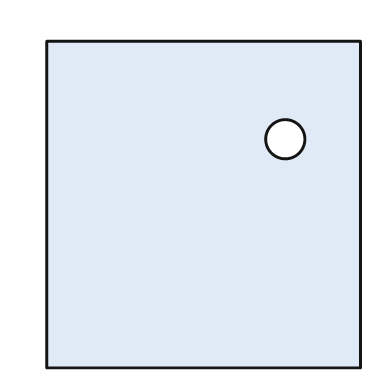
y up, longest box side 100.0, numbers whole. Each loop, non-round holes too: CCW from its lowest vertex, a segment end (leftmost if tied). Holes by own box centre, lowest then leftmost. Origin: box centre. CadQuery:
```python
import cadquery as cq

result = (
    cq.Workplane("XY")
    .moveTo(-48.0, -50.0)
    .lineTo(48.0, -50.0)
    .lineTo(48.0, 50.0)
    .lineTo(-48.0, 50.0)
    .close()
    .moveTo(25.0, 20.0)
    .circle(6.0)
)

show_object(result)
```